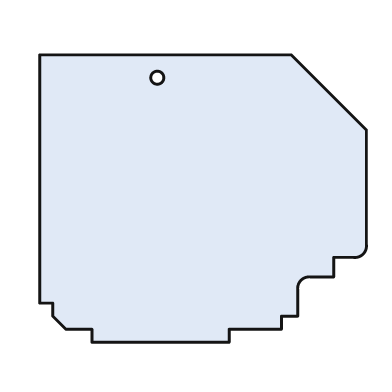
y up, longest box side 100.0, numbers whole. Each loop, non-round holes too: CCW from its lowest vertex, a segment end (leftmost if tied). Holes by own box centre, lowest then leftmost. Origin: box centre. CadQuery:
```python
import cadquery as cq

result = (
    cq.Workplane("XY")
    .moveTo(-34.0, -44.0)
    .lineTo(8.0, -44.0)
    .lineTo(8.0, -40.0)
    .lineTo(24.0, -40.0)
    .lineTo(24.0, -36.0)
    .lineTo(29.0, -36.0)
    .lineTo(29.0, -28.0)
    .threePointArc((30.0, -25.0), (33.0, -24.0))
    .lineTo(40.0, -24.0)
    .lineTo(40.0, -18.0)
    .lineTo(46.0, -18.0)
    .threePointArc((49.0, -17.0), (50.0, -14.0))
    .lineTo(50.0, 21.0)
    .lineTo(27.0, 44.0)
    .lineTo(-50.0, 44.0)
    .lineTo(-50.0, -32.0)
    .lineTo(-46.0, -32.0)
    .lineTo(-46.0, -36.0)
    .lineTo(-42.0, -40.0)
    .lineTo(-34.0, -40.0)
    .close()
    .moveTo(-14.0, 37.0)
    .circle(2.0)
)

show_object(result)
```